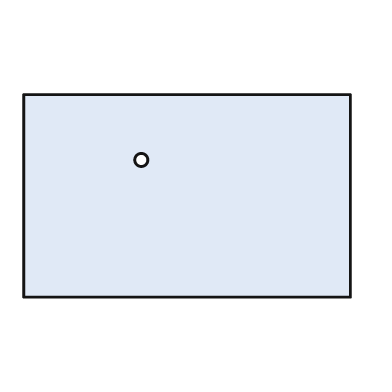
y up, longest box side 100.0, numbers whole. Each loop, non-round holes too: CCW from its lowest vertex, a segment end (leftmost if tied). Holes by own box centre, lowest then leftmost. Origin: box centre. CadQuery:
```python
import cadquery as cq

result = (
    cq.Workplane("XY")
    .moveTo(-50.0, -31.0)
    .lineTo(50.0, -31.0)
    .lineTo(50.0, 31.0)
    .lineTo(-50.0, 31.0)
    .close()
    .moveTo(-14.0, 11.0)
    .circle(2.0)
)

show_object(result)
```